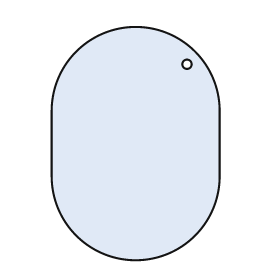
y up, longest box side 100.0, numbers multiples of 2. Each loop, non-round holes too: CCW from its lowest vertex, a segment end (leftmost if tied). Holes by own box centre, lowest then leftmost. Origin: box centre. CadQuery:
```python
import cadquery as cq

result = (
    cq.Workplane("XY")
    .moveTo(-36.0, -14.0)
    .threePointArc((0.0, -50.0), (36.0, -14.0))
    .lineTo(36.0, 14.0)
    .threePointArc((0.0, 50.0), (-36.0, 14.0))
    .close()
    .moveTo(22.0, 34.0)
    .circle(2.0)
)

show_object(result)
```